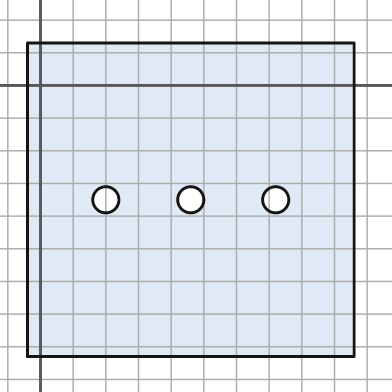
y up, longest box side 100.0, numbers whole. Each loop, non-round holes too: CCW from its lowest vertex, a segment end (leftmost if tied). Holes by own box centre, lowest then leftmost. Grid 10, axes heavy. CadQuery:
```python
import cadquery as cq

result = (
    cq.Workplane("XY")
    .moveTo(-4.0, -83.0)
    .lineTo(96.0, -83.0)
    .lineTo(96.0, 13.0)
    .lineTo(-4.0, 13.0)
    .close()
    .moveTo(20.0, -35.0)
    .circle(4.0)
    .moveTo(46.0, -35.0)
    .circle(4.0)
    .moveTo(72.0, -35.0)
    .circle(4.0)
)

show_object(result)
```